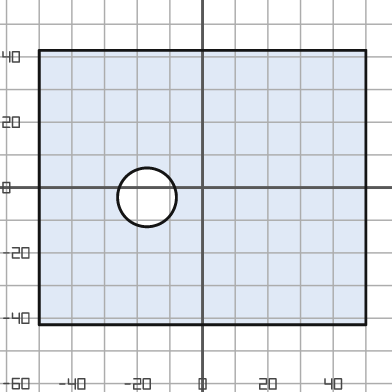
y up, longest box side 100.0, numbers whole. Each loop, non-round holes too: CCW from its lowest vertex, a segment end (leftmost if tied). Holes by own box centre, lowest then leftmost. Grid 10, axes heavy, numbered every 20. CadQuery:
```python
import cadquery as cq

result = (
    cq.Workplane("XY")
    .moveTo(-50.0, -42.0)
    .lineTo(50.0, -42.0)
    .lineTo(50.0, 42.0)
    .lineTo(-50.0, 42.0)
    .close()
    .moveTo(-17.0, -3.0)
    .circle(9.0)
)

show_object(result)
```